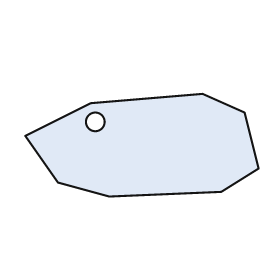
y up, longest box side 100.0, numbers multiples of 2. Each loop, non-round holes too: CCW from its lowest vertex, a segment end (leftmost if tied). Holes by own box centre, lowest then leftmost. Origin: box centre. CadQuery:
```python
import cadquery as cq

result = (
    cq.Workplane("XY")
    .moveTo(-14.0, -22.0)
    .lineTo(34.0, -20.0)
    .lineTo(50.0, -10.0)
    .lineTo(44.0, 14.0)
    .lineTo(26.0, 22.0)
    .lineTo(-22.0, 18.0)
    .lineTo(-50.0, 4.0)
    .lineTo(-36.0, -16.0)
    .close()
    .moveTo(-20.0, 10.0)
    .circle(4.0)
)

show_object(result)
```